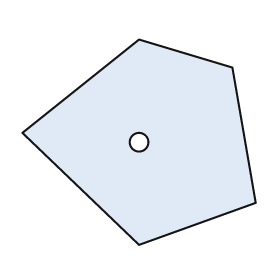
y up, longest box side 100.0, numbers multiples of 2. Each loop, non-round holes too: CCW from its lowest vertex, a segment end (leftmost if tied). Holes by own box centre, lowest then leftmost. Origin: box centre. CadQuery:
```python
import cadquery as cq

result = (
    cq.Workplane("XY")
    .moveTo(0.0, -44.0)
    .lineTo(50.0, -26.0)
    .lineTo(40.0, 32.0)
    .lineTo(0.0, 44.0)
    .lineTo(-50.0, 4.0)
    .close()
    .moveTo(0.0, 0.0)
    .circle(4.0)
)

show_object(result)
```